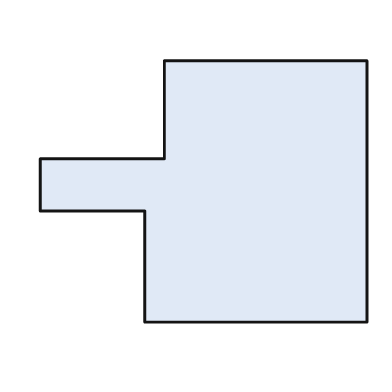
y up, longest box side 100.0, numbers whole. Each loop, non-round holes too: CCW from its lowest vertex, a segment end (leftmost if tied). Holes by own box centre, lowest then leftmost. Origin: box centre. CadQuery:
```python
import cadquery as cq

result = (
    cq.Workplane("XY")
    .moveTo(-18.0, -40.0)
    .lineTo(50.0, -40.0)
    .lineTo(50.0, 40.0)
    .lineTo(-12.0, 40.0)
    .lineTo(-12.0, 10.0)
    .lineTo(-50.0, 10.0)
    .lineTo(-50.0, -6.0)
    .lineTo(-18.0, -6.0)
    .close()
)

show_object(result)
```